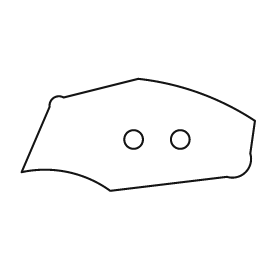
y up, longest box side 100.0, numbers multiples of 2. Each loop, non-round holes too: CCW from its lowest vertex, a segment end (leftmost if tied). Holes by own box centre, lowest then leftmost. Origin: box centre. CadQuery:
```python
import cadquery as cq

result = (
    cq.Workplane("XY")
    .moveTo(-12.0, -24.0)
    .lineTo(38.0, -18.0)
    .threePointArc((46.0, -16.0), (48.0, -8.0))
    .lineTo(50.0, 6.0)
    .threePointArc((26.0, 18.0), (0.0, 24.0))
    .lineTo(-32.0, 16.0)
    .threePointArc((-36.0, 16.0), (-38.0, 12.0))
    .lineTo(-50.0, -16.0)
    .threePointArc((-30.0, -16.0), (-12.0, -24.0))
    .close()
    .moveTo(-2.0, -2.0)
    .circle(4.0)
    .moveTo(18.0, -2.0)
    .circle(4.0)
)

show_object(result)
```